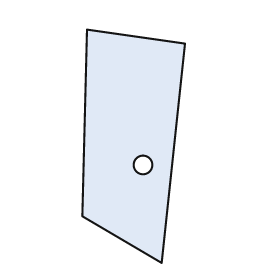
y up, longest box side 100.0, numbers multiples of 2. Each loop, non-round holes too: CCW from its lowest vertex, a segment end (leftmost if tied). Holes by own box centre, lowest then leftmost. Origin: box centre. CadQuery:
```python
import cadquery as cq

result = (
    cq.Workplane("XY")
    .moveTo(12.0, -50.0)
    .lineTo(22.0, 44.0)
    .lineTo(-20.0, 50.0)
    .lineTo(-22.0, -30.0)
    .close()
    .moveTo(4.0, -8.0)
    .circle(4.0)
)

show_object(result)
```